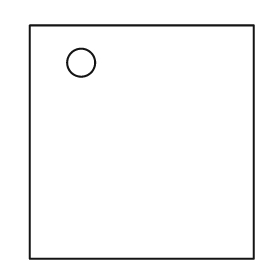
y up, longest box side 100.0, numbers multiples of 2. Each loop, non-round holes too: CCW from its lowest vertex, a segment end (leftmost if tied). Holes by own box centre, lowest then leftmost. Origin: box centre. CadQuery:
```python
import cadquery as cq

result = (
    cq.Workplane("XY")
    .moveTo(-48.0, -50.0)
    .lineTo(48.0, -50.0)
    .lineTo(48.0, 50.0)
    .lineTo(-48.0, 50.0)
    .close()
    .moveTo(-26.0, 34.0)
    .circle(6.0)
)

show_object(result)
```